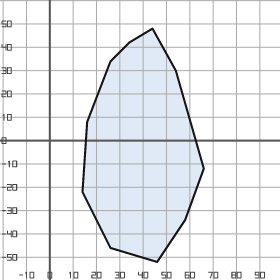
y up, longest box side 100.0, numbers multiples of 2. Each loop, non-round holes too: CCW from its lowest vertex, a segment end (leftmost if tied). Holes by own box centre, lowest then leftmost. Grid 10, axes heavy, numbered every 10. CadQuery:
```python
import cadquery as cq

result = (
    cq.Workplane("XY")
    .moveTo(46.0, -52.0)
    .lineTo(58.0, -34.0)
    .lineTo(66.0, -12.0)
    .lineTo(54.0, 30.0)
    .lineTo(44.0, 48.0)
    .lineTo(34.0, 42.0)
    .lineTo(26.0, 34.0)
    .lineTo(16.0, 8.0)
    .lineTo(14.0, -22.0)
    .lineTo(26.0, -46.0)
    .close()
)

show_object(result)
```